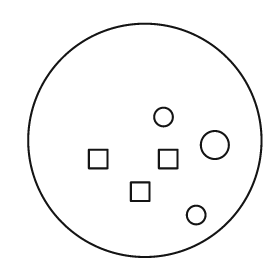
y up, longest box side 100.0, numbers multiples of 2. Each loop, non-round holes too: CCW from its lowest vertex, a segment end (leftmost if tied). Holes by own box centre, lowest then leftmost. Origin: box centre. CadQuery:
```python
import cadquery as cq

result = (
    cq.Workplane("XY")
    .moveTo(0.0, 0.0)
    .circle(50.0)
    .moveTo(22.0, -32.0)
    .circle(4.0)
    .moveTo(-6.0, -26.0)
    .lineTo(2.0, -26.0)
    .lineTo(2.0, -18.0)
    .lineTo(-6.0, -18.0)
    .close()
    .moveTo(-24.0, -12.0)
    .lineTo(-16.0, -12.0)
    .lineTo(-16.0, -4.0)
    .lineTo(-24.0, -4.0)
    .close()
    .moveTo(6.0, -12.0)
    .lineTo(14.0, -12.0)
    .lineTo(14.0, -4.0)
    .lineTo(6.0, -4.0)
    .close()
    .moveTo(30.0, -2.0)
    .circle(6.0)
    .moveTo(8.0, 10.0)
    .circle(4.0)
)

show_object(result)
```